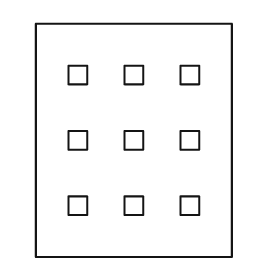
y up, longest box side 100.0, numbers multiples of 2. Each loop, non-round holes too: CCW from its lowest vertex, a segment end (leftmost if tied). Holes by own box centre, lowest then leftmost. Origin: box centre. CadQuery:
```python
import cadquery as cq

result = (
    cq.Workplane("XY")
    .moveTo(-42.0, -50.0)
    .lineTo(42.0, -50.0)
    .lineTo(42.0, 50.0)
    .lineTo(-42.0, 50.0)
    .close()
    .moveTo(-28.0, -32.0)
    .lineTo(-20.0, -32.0)
    .lineTo(-20.0, -24.0)
    .lineTo(-28.0, -24.0)
    .close()
    .moveTo(-4.0, -32.0)
    .lineTo(4.0, -32.0)
    .lineTo(4.0, -24.0)
    .lineTo(-4.0, -24.0)
    .close()
    .moveTo(20.0, -32.0)
    .lineTo(28.0, -32.0)
    .lineTo(28.0, -24.0)
    .lineTo(20.0, -24.0)
    .close()
    .moveTo(-28.0, -4.0)
    .lineTo(-20.0, -4.0)
    .lineTo(-20.0, 4.0)
    .lineTo(-28.0, 4.0)
    .close()
    .moveTo(-4.0, -4.0)
    .lineTo(4.0, -4.0)
    .lineTo(4.0, 4.0)
    .lineTo(-4.0, 4.0)
    .close()
    .moveTo(20.0, -4.0)
    .lineTo(28.0, -4.0)
    .lineTo(28.0, 4.0)
    .lineTo(20.0, 4.0)
    .close()
    .moveTo(-28.0, 24.0)
    .lineTo(-20.0, 24.0)
    .lineTo(-20.0, 32.0)
    .lineTo(-28.0, 32.0)
    .close()
    .moveTo(-4.0, 24.0)
    .lineTo(4.0, 24.0)
    .lineTo(4.0, 32.0)
    .lineTo(-4.0, 32.0)
    .close()
    .moveTo(20.0, 24.0)
    .lineTo(28.0, 24.0)
    .lineTo(28.0, 32.0)
    .lineTo(20.0, 32.0)
    .close()
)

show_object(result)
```